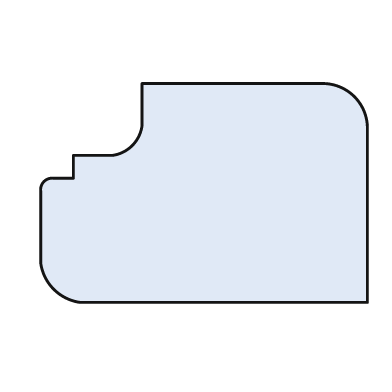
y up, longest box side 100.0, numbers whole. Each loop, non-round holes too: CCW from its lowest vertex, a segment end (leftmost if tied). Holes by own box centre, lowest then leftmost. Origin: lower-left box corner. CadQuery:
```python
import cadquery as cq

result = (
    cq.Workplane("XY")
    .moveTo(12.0, 0.0)
    .lineTo(100.0, 0.0)
    .lineTo(100.0, 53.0)
    .threePointArc((96.0, 63.0), (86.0, 67.0))
    .lineTo(31.0, 67.0)
    .lineTo(31.0, 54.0)
    .threePointArc((28.0, 48.0), (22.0, 45.0))
    .lineTo(10.0, 45.0)
    .lineTo(10.0, 38.0)
    .lineTo(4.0, 38.0)
    .threePointArc((1.0, 37.0), (0.0, 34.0))
    .lineTo(0.0, 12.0)
    .threePointArc((4.0, 4.0), (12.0, 0.0))
    .close()
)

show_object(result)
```